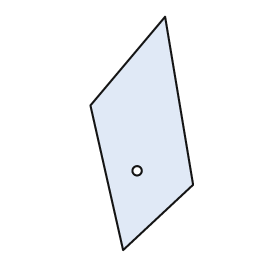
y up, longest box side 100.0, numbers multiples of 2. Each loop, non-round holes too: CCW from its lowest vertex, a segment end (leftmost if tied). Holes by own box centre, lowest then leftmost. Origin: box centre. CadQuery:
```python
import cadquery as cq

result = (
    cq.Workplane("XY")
    .moveTo(-8.0, -50.0)
    .lineTo(22.0, -22.0)
    .lineTo(10.0, 50.0)
    .lineTo(-22.0, 12.0)
    .close()
    .moveTo(-2.0, -16.0)
    .circle(2.0)
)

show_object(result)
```